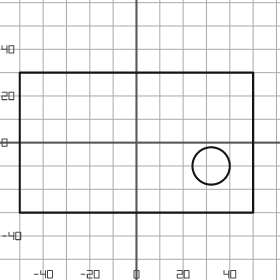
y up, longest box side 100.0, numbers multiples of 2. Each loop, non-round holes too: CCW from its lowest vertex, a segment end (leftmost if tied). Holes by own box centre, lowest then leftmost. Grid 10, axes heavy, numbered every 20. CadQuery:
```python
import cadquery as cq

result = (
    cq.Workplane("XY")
    .moveTo(-50.0, -30.0)
    .lineTo(50.0, -30.0)
    .lineTo(50.0, 30.0)
    .lineTo(-50.0, 30.0)
    .close()
    .moveTo(32.0, -10.0)
    .circle(8.0)
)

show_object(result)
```